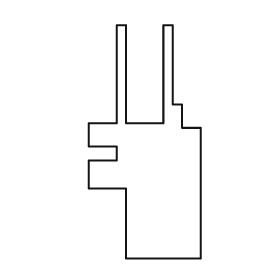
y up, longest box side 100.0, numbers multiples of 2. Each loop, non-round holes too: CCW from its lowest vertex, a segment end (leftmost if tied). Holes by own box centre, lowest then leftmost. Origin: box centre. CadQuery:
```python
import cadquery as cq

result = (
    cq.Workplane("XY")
    .moveTo(-8.0, -50.0)
    .lineTo(24.0, -50.0)
    .lineTo(24.0, 6.0)
    .lineTo(16.0, 6.0)
    .lineTo(16.0, 16.0)
    .lineTo(12.0, 16.0)
    .lineTo(12.0, 50.0)
    .lineTo(8.0, 50.0)
    .lineTo(8.0, 8.0)
    .lineTo(-8.0, 8.0)
    .lineTo(-8.0, 50.0)
    .lineTo(-12.0, 50.0)
    .lineTo(-12.0, 8.0)
    .lineTo(-24.0, 8.0)
    .lineTo(-24.0, -2.0)
    .lineTo(-12.0, -2.0)
    .lineTo(-12.0, -8.0)
    .lineTo(-24.0, -8.0)
    .lineTo(-24.0, -20.0)
    .lineTo(-8.0, -20.0)
    .close()
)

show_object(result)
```